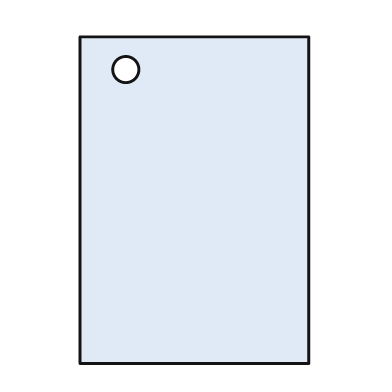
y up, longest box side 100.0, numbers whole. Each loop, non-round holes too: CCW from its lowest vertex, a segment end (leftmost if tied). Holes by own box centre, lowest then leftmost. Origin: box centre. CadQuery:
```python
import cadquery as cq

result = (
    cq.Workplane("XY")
    .moveTo(-35.0, -50.0)
    .lineTo(35.0, -50.0)
    .lineTo(35.0, 50.0)
    .lineTo(-35.0, 50.0)
    .close()
    .moveTo(-21.0, 40.0)
    .circle(4.0)
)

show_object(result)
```